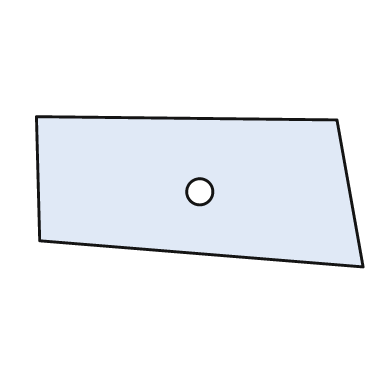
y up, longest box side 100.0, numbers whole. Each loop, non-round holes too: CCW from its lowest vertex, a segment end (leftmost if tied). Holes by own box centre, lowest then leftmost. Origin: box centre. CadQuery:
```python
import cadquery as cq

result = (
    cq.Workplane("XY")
    .moveTo(50.0, -23.0)
    .lineTo(42.0, 22.0)
    .lineTo(-50.0, 23.0)
    .lineTo(-49.0, -15.0)
    .close()
    .moveTo(0.0, 0.0)
    .circle(4.0)
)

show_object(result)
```